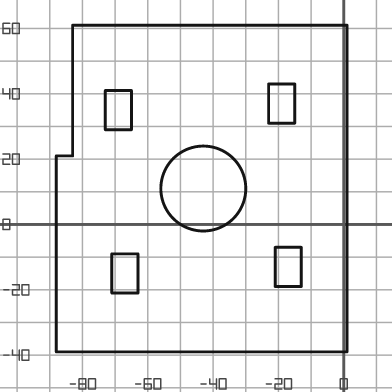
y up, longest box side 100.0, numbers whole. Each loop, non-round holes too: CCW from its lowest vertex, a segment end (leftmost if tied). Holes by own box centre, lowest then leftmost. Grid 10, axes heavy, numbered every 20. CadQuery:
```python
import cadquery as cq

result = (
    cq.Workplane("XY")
    .moveTo(-88.0, -39.0)
    .lineTo(1.0, -39.0)
    .lineTo(1.0, 61.0)
    .lineTo(-83.0, 61.0)
    .lineTo(-83.0, 21.0)
    .lineTo(-88.0, 21.0)
    .close()
    .moveTo(-71.0, -21.0)
    .lineTo(-63.0, -21.0)
    .lineTo(-63.0, -9.0)
    .lineTo(-71.0, -9.0)
    .close()
    .moveTo(-21.0, -19.0)
    .lineTo(-13.0, -19.0)
    .lineTo(-13.0, -7.0)
    .lineTo(-21.0, -7.0)
    .close()
    .moveTo(-43.0, 11.0)
    .circle(13.0)
    .moveTo(-73.0, 29.0)
    .lineTo(-65.0, 29.0)
    .lineTo(-65.0, 41.0)
    .lineTo(-73.0, 41.0)
    .close()
    .moveTo(-23.0, 31.0)
    .lineTo(-15.0, 31.0)
    .lineTo(-15.0, 43.0)
    .lineTo(-23.0, 43.0)
    .close()
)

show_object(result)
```